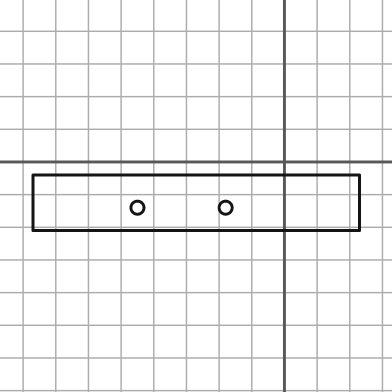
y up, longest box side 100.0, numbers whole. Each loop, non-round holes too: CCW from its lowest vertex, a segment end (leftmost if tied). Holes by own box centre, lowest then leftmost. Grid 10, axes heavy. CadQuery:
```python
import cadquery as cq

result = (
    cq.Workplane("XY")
    .moveTo(-77.0, -21.0)
    .lineTo(23.0, -21.0)
    .lineTo(23.0, -4.0)
    .lineTo(-77.0, -4.0)
    .close()
    .moveTo(-45.0, -14.0)
    .circle(2.0)
    .moveTo(-18.0, -14.0)
    .circle(2.0)
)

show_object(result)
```